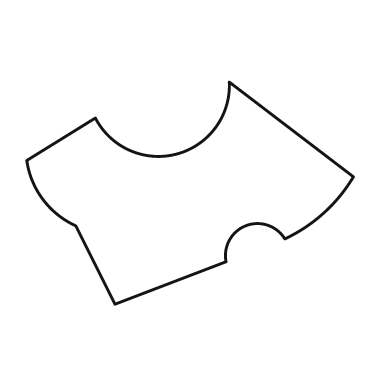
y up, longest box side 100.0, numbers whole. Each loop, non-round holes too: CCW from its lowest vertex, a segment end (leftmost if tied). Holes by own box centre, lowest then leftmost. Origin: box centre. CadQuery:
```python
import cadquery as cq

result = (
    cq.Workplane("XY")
    .moveTo(-23.0, -34.0)
    .lineTo(11.0, -21.0)
    .threePointArc((17.0, -10.0), (29.0, -14.0))
    .threePointArc((41.0, -6.0), (50.0, 5.0))
    .lineTo(12.0, 34.0)
    .threePointArc((-4.0, 12.0), (-29.0, 23.0))
    .lineTo(-50.0, 10.0)
    .threePointArc((-45.0, -2.0), (-35.0, -10.0))
    .close()
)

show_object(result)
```